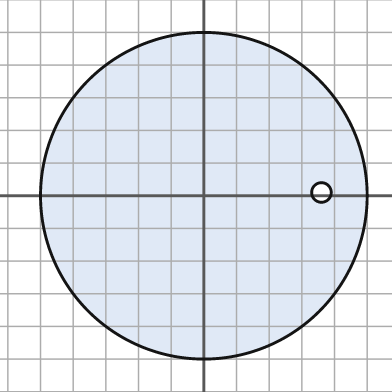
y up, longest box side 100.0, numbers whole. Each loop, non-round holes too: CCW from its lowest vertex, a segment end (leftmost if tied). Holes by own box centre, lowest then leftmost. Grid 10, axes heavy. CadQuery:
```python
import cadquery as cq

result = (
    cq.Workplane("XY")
    .moveTo(0.0, 0.0)
    .circle(50.0)
    .moveTo(36.0, 1.0)
    .circle(3.0)
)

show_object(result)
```